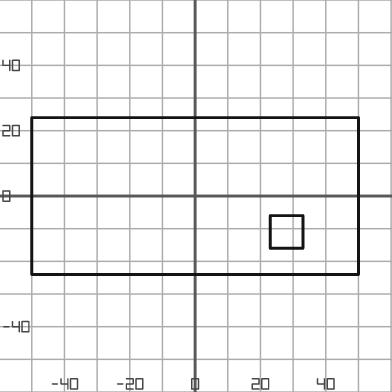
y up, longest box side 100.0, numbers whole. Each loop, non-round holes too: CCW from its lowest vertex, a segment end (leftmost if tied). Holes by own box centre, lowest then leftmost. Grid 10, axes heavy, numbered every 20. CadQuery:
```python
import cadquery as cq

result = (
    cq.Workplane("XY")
    .moveTo(-50.0, -24.0)
    .lineTo(50.0, -24.0)
    .lineTo(50.0, 24.0)
    .lineTo(-50.0, 24.0)
    .close()
    .moveTo(23.0, -16.0)
    .lineTo(33.0, -16.0)
    .lineTo(33.0, -6.0)
    .lineTo(23.0, -6.0)
    .close()
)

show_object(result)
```